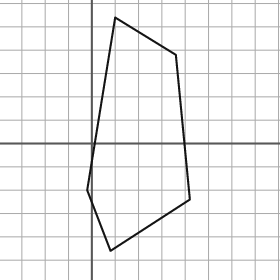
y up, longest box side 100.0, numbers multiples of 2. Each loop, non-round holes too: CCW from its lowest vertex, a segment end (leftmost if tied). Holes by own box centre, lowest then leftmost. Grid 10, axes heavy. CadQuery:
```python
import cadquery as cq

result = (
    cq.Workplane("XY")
    .moveTo(8.0, -46.0)
    .lineTo(42.0, -24.0)
    .lineTo(36.0, 38.0)
    .lineTo(10.0, 54.0)
    .lineTo(-2.0, -20.0)
    .close()
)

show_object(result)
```